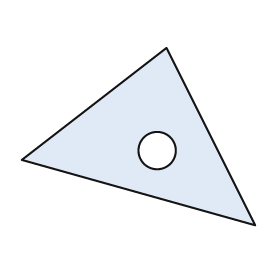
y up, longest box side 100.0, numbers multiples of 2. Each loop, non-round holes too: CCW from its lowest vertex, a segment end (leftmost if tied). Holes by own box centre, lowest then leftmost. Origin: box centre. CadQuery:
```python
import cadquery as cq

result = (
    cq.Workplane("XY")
    .moveTo(50.0, -38.0)
    .lineTo(12.0, 38.0)
    .lineTo(-50.0, -10.0)
    .close()
    .moveTo(8.0, -6.0)
    .circle(8.0)
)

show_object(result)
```